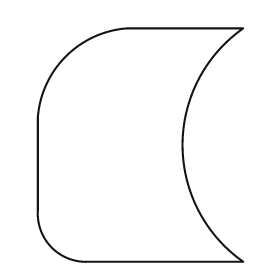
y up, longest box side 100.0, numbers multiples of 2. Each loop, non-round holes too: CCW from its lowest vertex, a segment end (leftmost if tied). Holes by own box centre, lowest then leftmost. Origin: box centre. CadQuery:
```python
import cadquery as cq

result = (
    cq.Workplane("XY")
    .moveTo(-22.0, -50.0)
    .lineTo(44.0, -50.0)
    .threePointArc((18.0, 0.0), (44.0, 50.0))
    .lineTo(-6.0, 50.0)
    .threePointArc((-32.0, 38.0), (-44.0, 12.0))
    .lineTo(-44.0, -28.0)
    .threePointArc((-38.0, -44.0), (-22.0, -50.0))
    .close()
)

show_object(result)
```